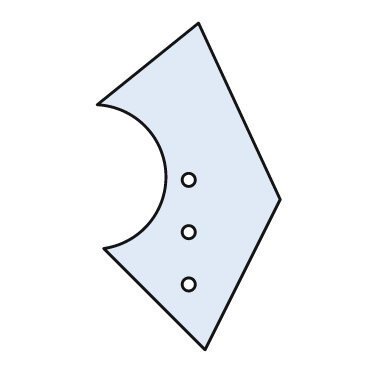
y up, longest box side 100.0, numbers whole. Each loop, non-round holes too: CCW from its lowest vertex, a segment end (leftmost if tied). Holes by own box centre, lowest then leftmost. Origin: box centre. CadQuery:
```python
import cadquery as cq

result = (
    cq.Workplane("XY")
    .moveTo(5.0, -50.0)
    .lineTo(28.0, -4.0)
    .lineTo(3.0, 50.0)
    .lineTo(-28.0, 25.0)
    .threePointArc((-7.0, 4.0), (-26.0, -19.0))
    .close()
    .moveTo(0.0, -30.0)
    .circle(2.0)
    .moveTo(0.0, -14.0)
    .circle(2.0)
    .moveTo(0.0, 2.0)
    .circle(2.0)
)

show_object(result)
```